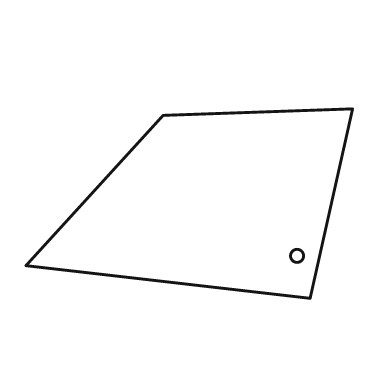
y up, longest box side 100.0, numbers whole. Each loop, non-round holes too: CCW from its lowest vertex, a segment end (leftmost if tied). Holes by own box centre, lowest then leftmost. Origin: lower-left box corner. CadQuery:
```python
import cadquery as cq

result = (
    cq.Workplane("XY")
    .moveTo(87.0, 0.0)
    .lineTo(100.0, 58.0)
    .lineTo(42.0, 56.0)
    .lineTo(0.0, 10.0)
    .close()
    .moveTo(83.0, 13.0)
    .circle(2.0)
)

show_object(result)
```